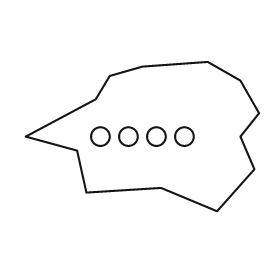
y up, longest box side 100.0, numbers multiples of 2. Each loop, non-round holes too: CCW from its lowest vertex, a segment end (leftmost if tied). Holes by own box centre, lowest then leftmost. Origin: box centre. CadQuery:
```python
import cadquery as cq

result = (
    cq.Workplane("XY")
    .moveTo(32.0, -32.0)
    .lineTo(48.0, -14.0)
    .lineTo(42.0, 0.0)
    .lineTo(50.0, 10.0)
    .lineTo(42.0, 24.0)
    .lineTo(28.0, 32.0)
    .lineTo(0.0, 30.0)
    .lineTo(-14.0, 26.0)
    .lineTo(-20.0, 16.0)
    .lineTo(-50.0, 0.0)
    .lineTo(-28.0, -6.0)
    .lineTo(-24.0, -24.0)
    .lineTo(8.0, -22.0)
    .close()
    .moveTo(-18.0, 0.0)
    .circle(4.0)
    .moveTo(-6.0, 0.0)
    .circle(4.0)
    .moveTo(6.0, 0.0)
    .circle(4.0)
    .moveTo(18.0, 0.0)
    .circle(4.0)
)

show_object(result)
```